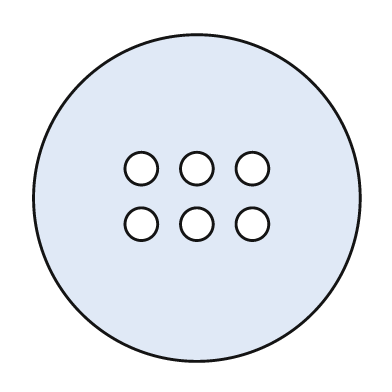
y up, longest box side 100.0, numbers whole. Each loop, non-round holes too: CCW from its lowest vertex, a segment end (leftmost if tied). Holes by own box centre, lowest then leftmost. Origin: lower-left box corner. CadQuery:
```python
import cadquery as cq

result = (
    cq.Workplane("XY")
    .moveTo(50.0, 50.0)
    .circle(50.0)
    .moveTo(33.0, 42.0)
    .circle(5.0)
    .moveTo(50.0, 42.0)
    .circle(5.0)
    .moveTo(67.0, 42.0)
    .circle(5.0)
    .moveTo(33.0, 59.0)
    .circle(5.0)
    .moveTo(50.0, 59.0)
    .circle(5.0)
    .moveTo(67.0, 59.0)
    .circle(5.0)
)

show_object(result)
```